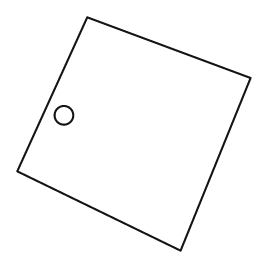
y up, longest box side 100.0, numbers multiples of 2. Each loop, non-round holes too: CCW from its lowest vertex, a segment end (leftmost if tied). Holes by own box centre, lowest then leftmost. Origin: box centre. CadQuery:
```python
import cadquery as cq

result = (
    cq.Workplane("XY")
    .moveTo(20.0, -50.0)
    .lineTo(50.0, 24.0)
    .lineTo(-20.0, 50.0)
    .lineTo(-50.0, -16.0)
    .close()
    .moveTo(-30.0, 8.0)
    .circle(4.0)
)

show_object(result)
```